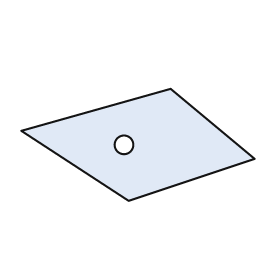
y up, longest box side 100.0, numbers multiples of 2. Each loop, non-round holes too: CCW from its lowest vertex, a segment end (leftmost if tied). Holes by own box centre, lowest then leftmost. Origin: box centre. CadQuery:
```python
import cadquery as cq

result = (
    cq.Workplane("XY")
    .moveTo(-4.0, -24.0)
    .lineTo(50.0, -6.0)
    .lineTo(14.0, 24.0)
    .lineTo(-50.0, 6.0)
    .close()
    .moveTo(-6.0, 0.0)
    .circle(4.0)
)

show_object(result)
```